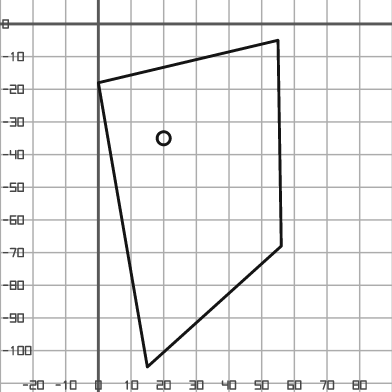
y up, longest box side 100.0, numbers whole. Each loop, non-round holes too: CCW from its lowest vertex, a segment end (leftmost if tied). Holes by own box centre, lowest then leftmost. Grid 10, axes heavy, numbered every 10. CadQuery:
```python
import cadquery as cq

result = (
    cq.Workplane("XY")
    .moveTo(15.0, -105.0)
    .lineTo(56.0, -68.0)
    .lineTo(55.0, -5.0)
    .lineTo(0.0, -18.0)
    .close()
    .moveTo(20.0, -35.0)
    .circle(2.0)
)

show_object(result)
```